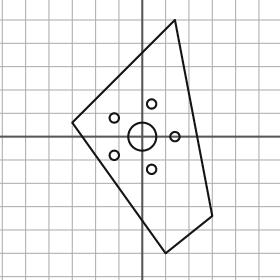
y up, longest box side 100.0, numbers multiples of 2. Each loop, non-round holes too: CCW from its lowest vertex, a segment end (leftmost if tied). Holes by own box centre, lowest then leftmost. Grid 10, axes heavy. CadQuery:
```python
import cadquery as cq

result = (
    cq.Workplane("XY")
    .moveTo(10.0, -50.0)
    .lineTo(30.0, -34.0)
    .lineTo(14.0, 50.0)
    .lineTo(-30.0, 6.0)
    .close()
    .moveTo(4.0, -14.0)
    .circle(2.0)
    .moveTo(-12.0, -8.0)
    .circle(2.0)
    .moveTo(0.0, 0.0)
    .circle(6.0)
    .moveTo(14.0, 0.0)
    .circle(2.0)
    .moveTo(-12.0, 8.0)
    .circle(2.0)
    .moveTo(4.0, 14.0)
    .circle(2.0)
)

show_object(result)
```